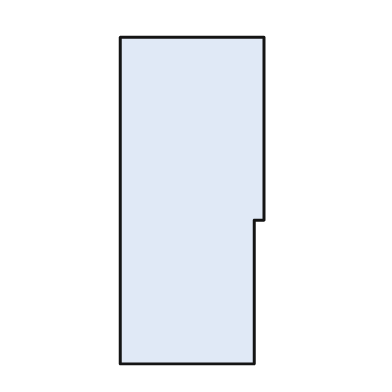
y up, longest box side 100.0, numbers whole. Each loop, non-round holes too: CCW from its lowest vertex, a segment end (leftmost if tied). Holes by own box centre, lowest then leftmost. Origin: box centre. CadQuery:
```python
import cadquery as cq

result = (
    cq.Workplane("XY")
    .moveTo(-22.0, -50.0)
    .lineTo(19.0, -50.0)
    .lineTo(19.0, -6.0)
    .lineTo(22.0, -6.0)
    .lineTo(22.0, 50.0)
    .lineTo(-22.0, 50.0)
    .close()
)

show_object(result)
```